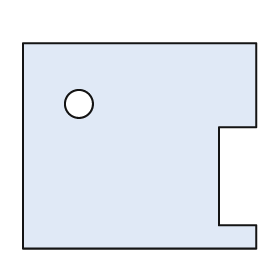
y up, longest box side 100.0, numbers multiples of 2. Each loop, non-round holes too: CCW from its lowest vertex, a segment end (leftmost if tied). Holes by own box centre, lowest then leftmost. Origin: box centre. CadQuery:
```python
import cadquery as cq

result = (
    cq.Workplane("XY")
    .moveTo(-50.0, -44.0)
    .lineTo(50.0, -44.0)
    .lineTo(50.0, -34.0)
    .lineTo(34.0, -34.0)
    .lineTo(34.0, 8.0)
    .lineTo(50.0, 8.0)
    .lineTo(50.0, 44.0)
    .lineTo(-50.0, 44.0)
    .close()
    .moveTo(-26.0, 18.0)
    .circle(6.0)
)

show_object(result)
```